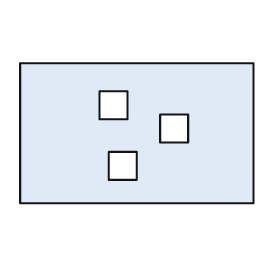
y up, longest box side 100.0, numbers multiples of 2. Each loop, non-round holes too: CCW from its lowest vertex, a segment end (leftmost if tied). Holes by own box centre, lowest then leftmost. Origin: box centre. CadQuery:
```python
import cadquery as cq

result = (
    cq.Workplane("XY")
    .moveTo(-50.0, -30.0)
    .lineTo(50.0, -30.0)
    .lineTo(50.0, 30.0)
    .lineTo(-50.0, 30.0)
    .close()
    .moveTo(-12.0, -20.0)
    .lineTo(0.0, -20.0)
    .lineTo(0.0, -8.0)
    .lineTo(-12.0, -8.0)
    .close()
    .moveTo(10.0, -4.0)
    .lineTo(22.0, -4.0)
    .lineTo(22.0, 8.0)
    .lineTo(10.0, 8.0)
    .close()
    .moveTo(-16.0, 6.0)
    .lineTo(-4.0, 6.0)
    .lineTo(-4.0, 18.0)
    .lineTo(-16.0, 18.0)
    .close()
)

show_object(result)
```